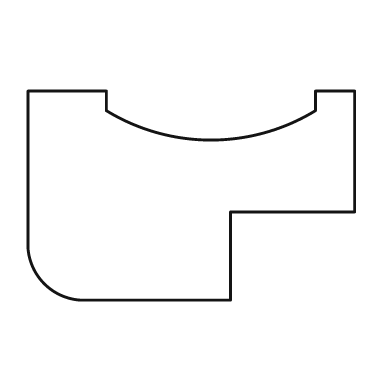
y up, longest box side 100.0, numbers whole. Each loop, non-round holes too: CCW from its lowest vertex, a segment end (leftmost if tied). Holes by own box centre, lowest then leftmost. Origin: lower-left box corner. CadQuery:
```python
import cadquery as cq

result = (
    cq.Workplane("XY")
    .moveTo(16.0, 0.0)
    .lineTo(62.0, 0.0)
    .lineTo(62.0, 27.0)
    .lineTo(100.0, 27.0)
    .lineTo(100.0, 64.0)
    .lineTo(88.0, 64.0)
    .lineTo(88.0, 58.0)
    .threePointArc((56.0, 49.0), (24.0, 58.0))
    .lineTo(24.0, 64.0)
    .lineTo(0.0, 64.0)
    .lineTo(0.0, 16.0)
    .threePointArc((5.0, 5.0), (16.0, 0.0))
    .close()
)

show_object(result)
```